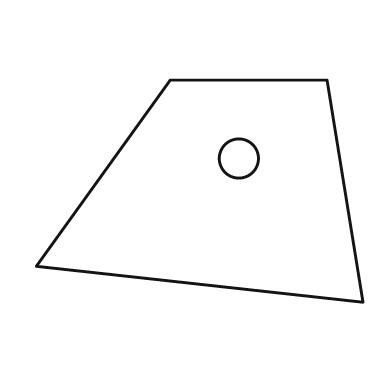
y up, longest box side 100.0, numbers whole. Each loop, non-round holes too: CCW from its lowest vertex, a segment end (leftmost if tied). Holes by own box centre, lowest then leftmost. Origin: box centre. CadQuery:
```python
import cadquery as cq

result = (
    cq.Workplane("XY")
    .moveTo(50.0, -34.0)
    .lineTo(39.0, 34.0)
    .lineTo(-9.0, 34.0)
    .lineTo(-50.0, -23.0)
    .close()
    .moveTo(12.0, 10.0)
    .circle(6.0)
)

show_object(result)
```